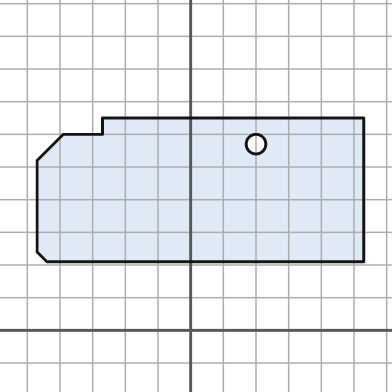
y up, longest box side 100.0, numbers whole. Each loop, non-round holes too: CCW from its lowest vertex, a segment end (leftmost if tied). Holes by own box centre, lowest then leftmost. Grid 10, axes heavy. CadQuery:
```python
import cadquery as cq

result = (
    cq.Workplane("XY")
    .moveTo(-44.0, 21.0)
    .lineTo(53.0, 21.0)
    .lineTo(53.0, 65.0)
    .lineTo(-27.0, 65.0)
    .lineTo(-27.0, 60.0)
    .lineTo(-39.0, 60.0)
    .lineTo(-47.0, 52.0)
    .lineTo(-47.0, 24.0)
    .close()
    .moveTo(20.0, 57.0)
    .circle(3.0)
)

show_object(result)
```